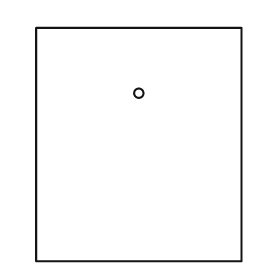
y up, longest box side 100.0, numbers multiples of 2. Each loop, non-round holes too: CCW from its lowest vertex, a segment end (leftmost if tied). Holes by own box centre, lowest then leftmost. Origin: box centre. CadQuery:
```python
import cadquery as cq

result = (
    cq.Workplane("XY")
    .moveTo(-44.0, -50.0)
    .lineTo(44.0, -50.0)
    .lineTo(44.0, 50.0)
    .lineTo(-44.0, 50.0)
    .close()
    .moveTo(0.0, 22.0)
    .circle(2.0)
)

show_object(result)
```